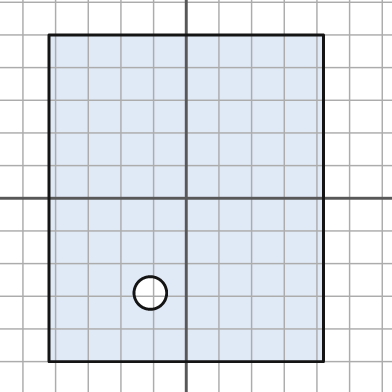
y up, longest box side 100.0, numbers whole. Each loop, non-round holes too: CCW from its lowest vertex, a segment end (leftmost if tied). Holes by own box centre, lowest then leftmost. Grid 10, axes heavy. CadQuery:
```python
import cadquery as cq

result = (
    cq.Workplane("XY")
    .moveTo(-42.0, -50.0)
    .lineTo(42.0, -50.0)
    .lineTo(42.0, 50.0)
    .lineTo(-42.0, 50.0)
    .close()
    .moveTo(-11.0, -29.0)
    .circle(5.0)
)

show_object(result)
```